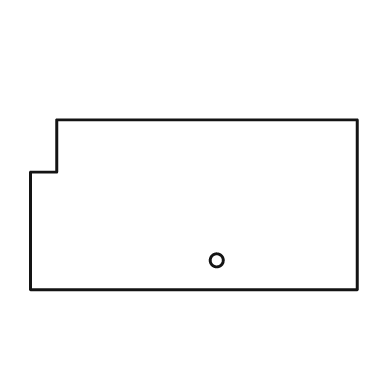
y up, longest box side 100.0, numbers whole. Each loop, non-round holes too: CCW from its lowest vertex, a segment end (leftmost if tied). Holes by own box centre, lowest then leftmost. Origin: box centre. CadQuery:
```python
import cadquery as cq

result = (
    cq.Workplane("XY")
    .moveTo(-50.0, -26.0)
    .lineTo(50.0, -26.0)
    .lineTo(50.0, 26.0)
    .lineTo(-42.0, 26.0)
    .lineTo(-42.0, 10.0)
    .lineTo(-50.0, 10.0)
    .close()
    .moveTo(7.0, -17.0)
    .circle(2.0)
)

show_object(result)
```